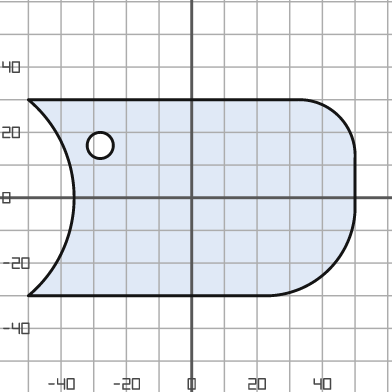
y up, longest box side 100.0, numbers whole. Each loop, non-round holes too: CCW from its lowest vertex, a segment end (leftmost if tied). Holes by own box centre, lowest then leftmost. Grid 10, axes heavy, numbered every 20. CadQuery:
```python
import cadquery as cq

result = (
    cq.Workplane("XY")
    .moveTo(-50.0, -30.0)
    .lineTo(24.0, -30.0)
    .threePointArc((42.0, -22.0), (50.0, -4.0))
    .lineTo(50.0, 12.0)
    .threePointArc((45.0, 25.0), (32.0, 30.0))
    .lineTo(-50.0, 30.0)
    .threePointArc((-36.0, 0.0), (-50.0, -30.0))
    .close()
    .moveTo(-28.0, 16.0)
    .circle(4.0)
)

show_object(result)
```